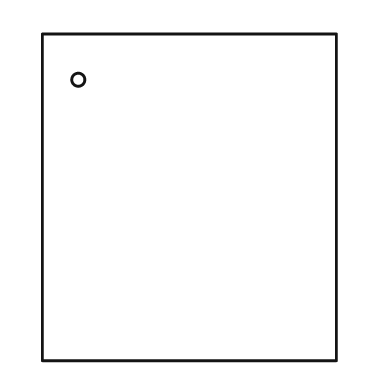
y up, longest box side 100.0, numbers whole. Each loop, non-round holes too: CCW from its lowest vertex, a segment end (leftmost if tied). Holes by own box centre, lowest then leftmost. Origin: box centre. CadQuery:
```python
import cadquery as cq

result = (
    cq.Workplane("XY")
    .moveTo(-45.0, -50.0)
    .lineTo(45.0, -50.0)
    .lineTo(45.0, 50.0)
    .lineTo(-45.0, 50.0)
    .close()
    .moveTo(-34.0, 36.0)
    .circle(2.0)
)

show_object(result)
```